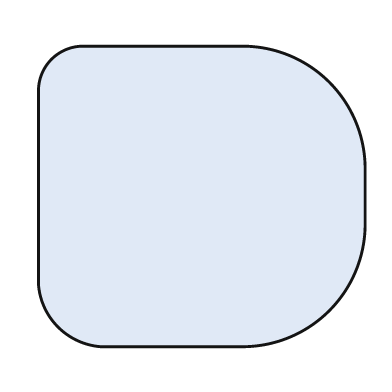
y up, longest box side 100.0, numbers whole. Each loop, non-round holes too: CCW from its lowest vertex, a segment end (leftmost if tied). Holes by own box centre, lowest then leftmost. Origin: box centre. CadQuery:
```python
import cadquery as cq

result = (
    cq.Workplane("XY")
    .moveTo(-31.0, -46.0)
    .lineTo(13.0, -46.0)
    .threePointArc((39.0, -35.0), (50.0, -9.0))
    .lineTo(50.0, 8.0)
    .threePointArc((39.0, 35.0), (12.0, 46.0))
    .lineTo(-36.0, 46.0)
    .threePointArc((-46.0, 42.0), (-50.0, 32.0))
    .lineTo(-50.0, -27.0)
    .threePointArc((-44.0, -40.0), (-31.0, -46.0))
    .close()
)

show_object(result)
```